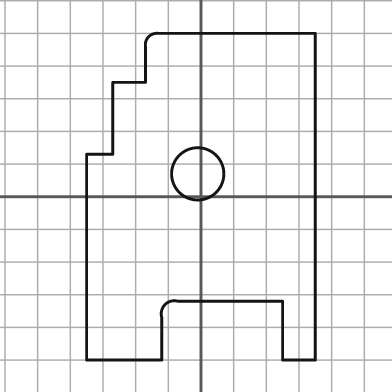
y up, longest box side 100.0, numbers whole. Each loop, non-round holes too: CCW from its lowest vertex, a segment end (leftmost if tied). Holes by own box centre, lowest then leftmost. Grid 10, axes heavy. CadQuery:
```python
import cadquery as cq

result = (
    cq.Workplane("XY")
    .moveTo(-35.0, -50.0)
    .lineTo(-12.0, -50.0)
    .lineTo(-12.0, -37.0)
    .threePointArc((-11.0, -33.0), (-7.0, -32.0))
    .lineTo(25.0, -32.0)
    .lineTo(25.0, -50.0)
    .lineTo(35.0, -50.0)
    .lineTo(35.0, 50.0)
    .lineTo(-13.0, 50.0)
    .threePointArc((-16.0, 49.0), (-17.0, 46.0))
    .lineTo(-17.0, 35.0)
    .lineTo(-27.0, 35.0)
    .lineTo(-27.0, 13.0)
    .lineTo(-35.0, 13.0)
    .close()
    .moveTo(-1.0, 7.0)
    .circle(8.0)
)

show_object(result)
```